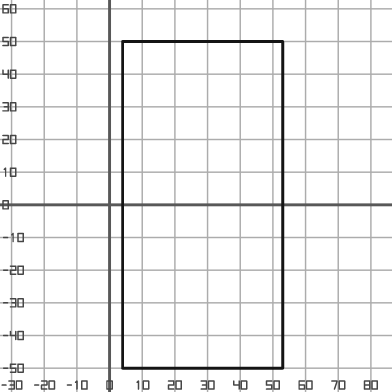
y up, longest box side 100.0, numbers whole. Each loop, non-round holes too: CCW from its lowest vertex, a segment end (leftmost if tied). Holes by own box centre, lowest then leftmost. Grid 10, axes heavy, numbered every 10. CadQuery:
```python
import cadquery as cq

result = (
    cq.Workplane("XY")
    .moveTo(4.0, -50.0)
    .lineTo(53.0, -50.0)
    .lineTo(53.0, 50.0)
    .lineTo(4.0, 50.0)
    .close()
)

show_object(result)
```